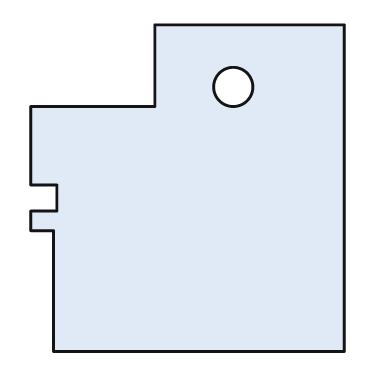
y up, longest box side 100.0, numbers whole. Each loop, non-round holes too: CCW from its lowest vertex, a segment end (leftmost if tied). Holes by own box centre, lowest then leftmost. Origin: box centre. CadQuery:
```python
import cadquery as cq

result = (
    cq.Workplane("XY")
    .moveTo(-41.0, -50.0)
    .lineTo(48.0, -50.0)
    .lineTo(48.0, 50.0)
    .lineTo(-10.0, 50.0)
    .lineTo(-10.0, 25.0)
    .lineTo(-48.0, 25.0)
    .lineTo(-48.0, 1.0)
    .lineTo(-40.0, 1.0)
    .lineTo(-40.0, -7.0)
    .lineTo(-48.0, -7.0)
    .lineTo(-48.0, -13.0)
    .lineTo(-41.0, -13.0)
    .close()
    .moveTo(14.0, 31.0)
    .circle(6.0)
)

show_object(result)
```